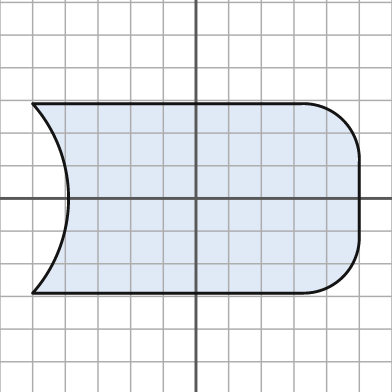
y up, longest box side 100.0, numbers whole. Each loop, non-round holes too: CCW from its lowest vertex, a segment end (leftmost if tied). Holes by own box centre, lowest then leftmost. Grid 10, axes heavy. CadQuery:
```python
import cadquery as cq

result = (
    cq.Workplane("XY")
    .moveTo(-50.0, -29.0)
    .lineTo(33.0, -29.0)
    .threePointArc((45.0, -24.0), (50.0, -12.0))
    .lineTo(50.0, 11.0)
    .threePointArc((45.0, 24.0), (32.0, 29.0))
    .lineTo(-50.0, 29.0)
    .threePointArc((-39.0, 0.0), (-50.0, -29.0))
    .close()
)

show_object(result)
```